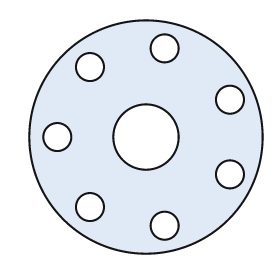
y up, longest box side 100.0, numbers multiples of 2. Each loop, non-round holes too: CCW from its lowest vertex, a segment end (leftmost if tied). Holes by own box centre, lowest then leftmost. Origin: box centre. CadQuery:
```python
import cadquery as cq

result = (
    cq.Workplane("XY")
    .moveTo(0.0, 0.0)
    .circle(50.0)
    .moveTo(8.0, -38.0)
    .circle(6.0)
    .moveTo(-24.0, -30.0)
    .circle(6.0)
    .moveTo(36.0, -16.0)
    .circle(6.0)
    .moveTo(-38.0, 0.0)
    .circle(6.0)
    .moveTo(0.0, 0.0)
    .circle(14.0)
    .moveTo(36.0, 16.0)
    .circle(6.0)
    .moveTo(-24.0, 30.0)
    .circle(6.0)
    .moveTo(8.0, 38.0)
    .circle(6.0)
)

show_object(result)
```